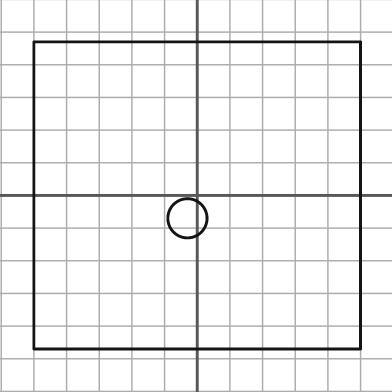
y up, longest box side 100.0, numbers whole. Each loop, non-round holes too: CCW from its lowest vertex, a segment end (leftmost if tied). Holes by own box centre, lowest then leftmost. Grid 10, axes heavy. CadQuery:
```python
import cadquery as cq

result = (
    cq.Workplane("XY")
    .moveTo(-50.0, -47.0)
    .lineTo(50.0, -47.0)
    .lineTo(50.0, 47.0)
    .lineTo(-50.0, 47.0)
    .close()
    .moveTo(-3.0, -7.0)
    .circle(6.0)
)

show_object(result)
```